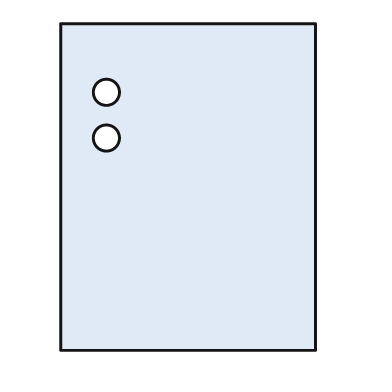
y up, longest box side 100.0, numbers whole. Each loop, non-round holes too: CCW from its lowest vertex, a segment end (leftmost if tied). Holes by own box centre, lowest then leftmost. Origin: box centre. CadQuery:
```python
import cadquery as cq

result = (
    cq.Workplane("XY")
    .moveTo(-39.0, -50.0)
    .lineTo(39.0, -50.0)
    .lineTo(39.0, 50.0)
    .lineTo(-39.0, 50.0)
    .close()
    .moveTo(-25.0, 15.0)
    .circle(4.0)
    .moveTo(-25.0, 29.0)
    .circle(4.0)
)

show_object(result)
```